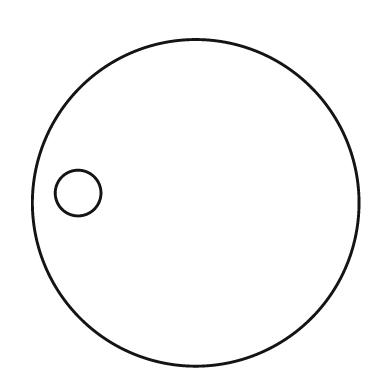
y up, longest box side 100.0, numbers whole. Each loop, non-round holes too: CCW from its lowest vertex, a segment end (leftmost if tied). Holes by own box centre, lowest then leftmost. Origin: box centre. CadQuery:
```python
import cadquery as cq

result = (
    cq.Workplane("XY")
    .moveTo(0.0, 0.0)
    .circle(50.0)
    .moveTo(-36.0, 3.0)
    .circle(7.0)
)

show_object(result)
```